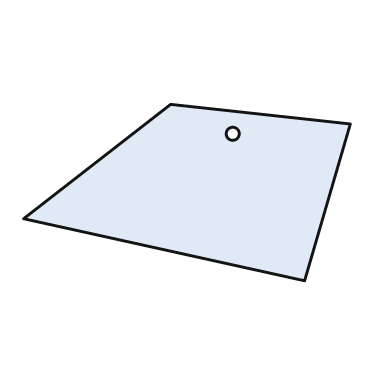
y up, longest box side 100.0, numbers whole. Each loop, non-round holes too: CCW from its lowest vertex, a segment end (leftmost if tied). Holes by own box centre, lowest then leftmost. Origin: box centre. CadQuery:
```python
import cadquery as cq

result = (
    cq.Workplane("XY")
    .moveTo(36.0, -27.0)
    .lineTo(50.0, 21.0)
    .lineTo(-5.0, 27.0)
    .lineTo(-50.0, -8.0)
    .close()
    .moveTo(14.0, 18.0)
    .circle(2.0)
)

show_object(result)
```